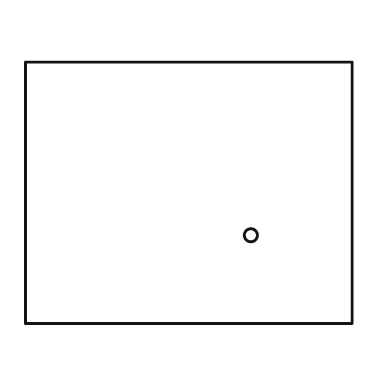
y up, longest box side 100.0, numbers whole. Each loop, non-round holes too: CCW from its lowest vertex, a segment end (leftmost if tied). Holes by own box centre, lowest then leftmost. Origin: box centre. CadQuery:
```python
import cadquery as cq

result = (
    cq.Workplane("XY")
    .moveTo(-50.0, -40.0)
    .lineTo(50.0, -40.0)
    .lineTo(50.0, 40.0)
    .lineTo(-50.0, 40.0)
    .close()
    .moveTo(19.0, -13.0)
    .circle(2.0)
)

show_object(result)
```